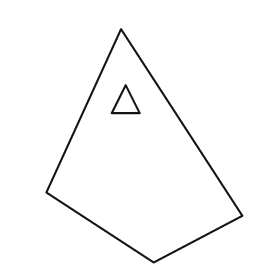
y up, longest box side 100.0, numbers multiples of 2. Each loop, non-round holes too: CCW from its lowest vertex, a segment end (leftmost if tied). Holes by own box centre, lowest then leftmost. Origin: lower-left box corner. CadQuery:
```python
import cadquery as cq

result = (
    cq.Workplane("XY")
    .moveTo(46.0, 0.0)
    .lineTo(84.0, 20.0)
    .lineTo(32.0, 100.0)
    .lineTo(0.0, 30.0)
    .close()
    .moveTo(28.0, 64.0)
    .lineTo(40.0, 64.0)
    .lineTo(34.0, 76.0)
    .close()
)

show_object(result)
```